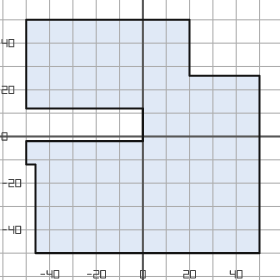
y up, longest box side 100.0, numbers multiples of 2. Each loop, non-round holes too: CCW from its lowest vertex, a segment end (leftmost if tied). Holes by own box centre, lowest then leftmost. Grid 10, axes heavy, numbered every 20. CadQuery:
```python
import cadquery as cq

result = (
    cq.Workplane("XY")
    .moveTo(-46.0, -50.0)
    .lineTo(50.0, -50.0)
    .lineTo(50.0, 26.0)
    .lineTo(20.0, 26.0)
    .lineTo(20.0, 50.0)
    .lineTo(-50.0, 50.0)
    .lineTo(-50.0, 12.0)
    .lineTo(0.0, 12.0)
    .lineTo(0.0, -2.0)
    .lineTo(-50.0, -2.0)
    .lineTo(-50.0, -12.0)
    .lineTo(-46.0, -12.0)
    .close()
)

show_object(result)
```